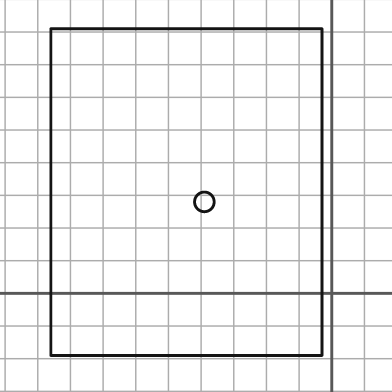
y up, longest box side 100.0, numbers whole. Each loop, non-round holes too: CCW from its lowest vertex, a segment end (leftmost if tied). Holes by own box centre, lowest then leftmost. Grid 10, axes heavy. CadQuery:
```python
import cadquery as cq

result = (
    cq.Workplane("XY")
    .moveTo(-86.0, -19.0)
    .lineTo(-3.0, -19.0)
    .lineTo(-3.0, 81.0)
    .lineTo(-86.0, 81.0)
    .close()
    .moveTo(-39.0, 28.0)
    .circle(3.0)
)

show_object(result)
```